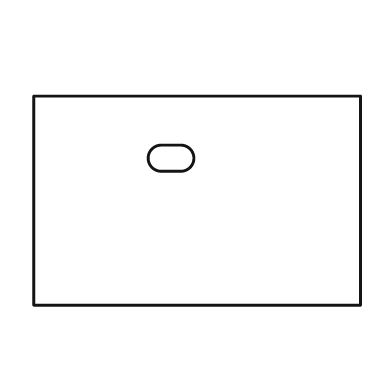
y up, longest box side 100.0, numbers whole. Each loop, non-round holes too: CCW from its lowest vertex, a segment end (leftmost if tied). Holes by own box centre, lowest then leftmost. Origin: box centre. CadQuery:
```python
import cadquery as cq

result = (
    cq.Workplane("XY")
    .moveTo(-50.0, -32.0)
    .lineTo(50.0, -32.0)
    .lineTo(50.0, 32.0)
    .lineTo(-50.0, 32.0)
    .close()
    .moveTo(-11.0, 9.0)
    .lineTo(-5.0, 9.0)
    .threePointArc((-1.0, 13.0), (-5.0, 17.0))
    .lineTo(-11.0, 17.0)
    .threePointArc((-15.0, 13.0), (-11.0, 9.0))
    .close()
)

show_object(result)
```